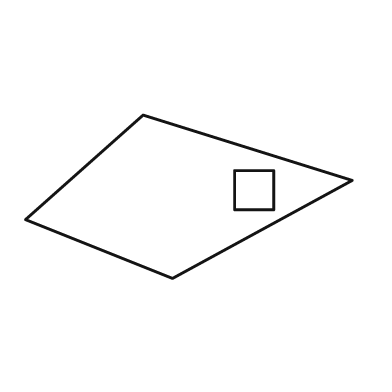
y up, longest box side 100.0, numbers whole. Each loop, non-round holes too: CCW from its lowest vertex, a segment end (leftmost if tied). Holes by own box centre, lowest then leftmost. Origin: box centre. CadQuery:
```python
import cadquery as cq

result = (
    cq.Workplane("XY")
    .moveTo(-5.0, -25.0)
    .lineTo(50.0, 5.0)
    .lineTo(-14.0, 25.0)
    .lineTo(-50.0, -7.0)
    .close()
    .moveTo(14.0, -4.0)
    .lineTo(26.0, -4.0)
    .lineTo(26.0, 8.0)
    .lineTo(14.0, 8.0)
    .close()
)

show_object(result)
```